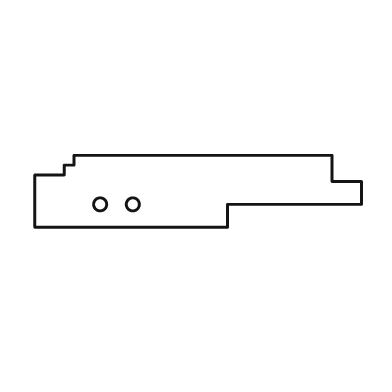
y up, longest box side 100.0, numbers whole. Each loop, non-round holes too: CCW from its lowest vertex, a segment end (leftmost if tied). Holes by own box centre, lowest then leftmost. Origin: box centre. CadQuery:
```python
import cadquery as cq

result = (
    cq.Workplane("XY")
    .moveTo(-50.0, -11.0)
    .lineTo(9.0, -11.0)
    .lineTo(9.0, -4.0)
    .lineTo(50.0, -4.0)
    .lineTo(50.0, 3.0)
    .lineTo(41.0, 3.0)
    .lineTo(41.0, 11.0)
    .lineTo(-38.0, 11.0)
    .lineTo(-38.0, 8.0)
    .lineTo(-41.0, 8.0)
    .lineTo(-41.0, 5.0)
    .lineTo(-50.0, 5.0)
    .close()
    .moveTo(-30.0, -4.0)
    .circle(2.0)
    .moveTo(-20.0, -4.0)
    .circle(2.0)
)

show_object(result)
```